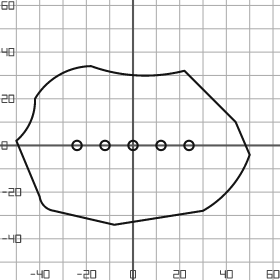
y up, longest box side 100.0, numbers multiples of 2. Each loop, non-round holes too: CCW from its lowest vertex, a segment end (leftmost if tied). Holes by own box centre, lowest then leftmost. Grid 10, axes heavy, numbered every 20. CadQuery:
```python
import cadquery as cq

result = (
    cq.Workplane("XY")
    .moveTo(-8.0, -34.0)
    .lineTo(30.0, -28.0)
    .threePointArc((42.0, -18.0), (50.0, -4.0))
    .lineTo(44.0, 10.0)
    .lineTo(22.0, 32.0)
    .threePointArc((2.0, 30.0), (-18.0, 34.0))
    .threePointArc((-32.0, 30.0), (-42.0, 20.0))
    .threePointArc((-44.0, 10.0), (-50.0, 2.0))
    .lineTo(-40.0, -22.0)
    .threePointArc((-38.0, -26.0), (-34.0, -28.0))
    .close()
    .moveTo(-24.0, 0.0)
    .circle(2.0)
    .moveTo(-12.0, 0.0)
    .circle(2.0)
    .moveTo(0.0, 0.0)
    .circle(2.0)
    .moveTo(12.0, 0.0)
    .circle(2.0)
    .moveTo(24.0, 0.0)
    .circle(2.0)
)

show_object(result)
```